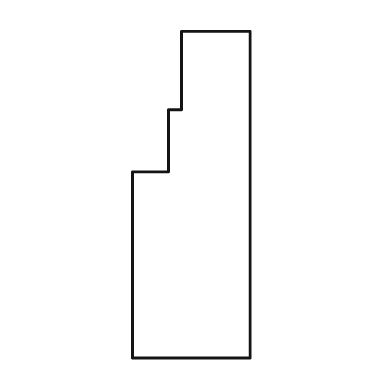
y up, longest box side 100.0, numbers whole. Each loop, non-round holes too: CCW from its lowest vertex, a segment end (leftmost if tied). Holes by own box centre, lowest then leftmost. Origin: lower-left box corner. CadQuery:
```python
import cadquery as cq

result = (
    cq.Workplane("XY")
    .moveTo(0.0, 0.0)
    .lineTo(36.0, 0.0)
    .lineTo(36.0, 100.0)
    .lineTo(15.0, 100.0)
    .lineTo(15.0, 76.0)
    .lineTo(11.0, 76.0)
    .lineTo(11.0, 57.0)
    .lineTo(0.0, 57.0)
    .close()
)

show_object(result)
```